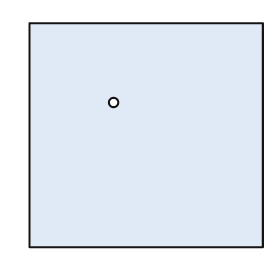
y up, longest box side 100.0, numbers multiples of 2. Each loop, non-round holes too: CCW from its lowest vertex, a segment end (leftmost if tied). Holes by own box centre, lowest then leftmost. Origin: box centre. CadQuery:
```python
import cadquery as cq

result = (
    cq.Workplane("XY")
    .moveTo(-50.0, -48.0)
    .lineTo(50.0, -48.0)
    .lineTo(50.0, 48.0)
    .lineTo(-50.0, 48.0)
    .close()
    .moveTo(-14.0, 14.0)
    .circle(2.0)
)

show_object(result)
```